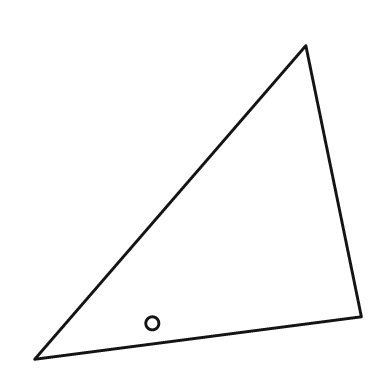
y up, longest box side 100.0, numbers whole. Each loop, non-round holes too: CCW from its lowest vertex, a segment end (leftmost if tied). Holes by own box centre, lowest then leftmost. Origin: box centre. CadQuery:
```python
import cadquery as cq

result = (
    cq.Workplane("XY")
    .moveTo(-50.0, -48.0)
    .lineTo(50.0, -35.0)
    .lineTo(33.0, 48.0)
    .close()
    .moveTo(-14.0, -37.0)
    .circle(2.0)
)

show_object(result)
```